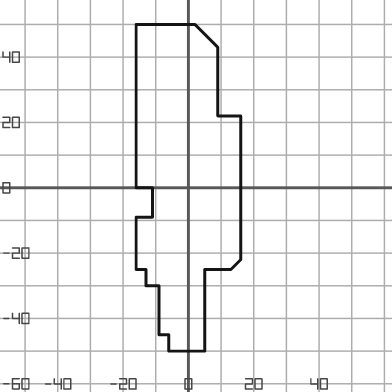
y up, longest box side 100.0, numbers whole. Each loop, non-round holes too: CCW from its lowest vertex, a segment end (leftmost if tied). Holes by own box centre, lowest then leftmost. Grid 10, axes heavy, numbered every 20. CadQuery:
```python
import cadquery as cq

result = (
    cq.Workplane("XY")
    .moveTo(-6.0, -50.0)
    .lineTo(5.0, -50.0)
    .lineTo(5.0, -25.0)
    .lineTo(13.0, -25.0)
    .lineTo(16.0, -22.0)
    .lineTo(16.0, 22.0)
    .lineTo(9.0, 22.0)
    .lineTo(9.0, 43.0)
    .lineTo(2.0, 50.0)
    .lineTo(-16.0, 50.0)
    .lineTo(-16.0, 0.0)
    .lineTo(-11.0, 0.0)
    .lineTo(-11.0, -9.0)
    .lineTo(-16.0, -9.0)
    .lineTo(-16.0, -25.0)
    .lineTo(-13.0, -25.0)
    .lineTo(-13.0, -30.0)
    .lineTo(-9.0, -30.0)
    .lineTo(-9.0, -45.0)
    .lineTo(-6.0, -45.0)
    .close()
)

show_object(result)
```